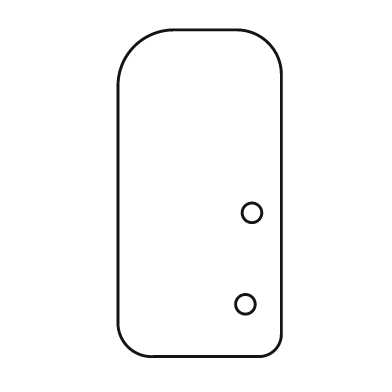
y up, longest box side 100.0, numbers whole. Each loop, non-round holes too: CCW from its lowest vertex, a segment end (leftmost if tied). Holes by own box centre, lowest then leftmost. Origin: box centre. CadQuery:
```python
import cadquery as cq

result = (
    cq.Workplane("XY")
    .moveTo(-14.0, -50.0)
    .lineTo(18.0, -50.0)
    .threePointArc((23.0, -48.0), (25.0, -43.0))
    .lineTo(25.0, 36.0)
    .threePointArc((21.0, 46.0), (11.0, 50.0))
    .lineTo(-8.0, 50.0)
    .threePointArc((-20.0, 45.0), (-25.0, 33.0))
    .lineTo(-25.0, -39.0)
    .threePointArc((-22.0, -47.0), (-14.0, -50.0))
    .close()
    .moveTo(14.0, -34.0)
    .circle(3.0)
    .moveTo(16.0, -6.0)
    .circle(3.0)
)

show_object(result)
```